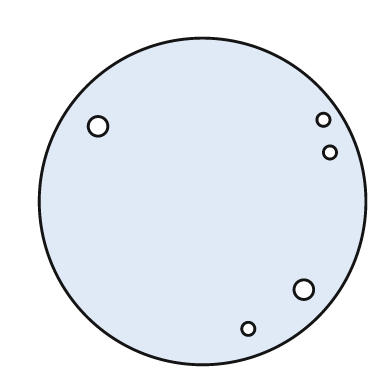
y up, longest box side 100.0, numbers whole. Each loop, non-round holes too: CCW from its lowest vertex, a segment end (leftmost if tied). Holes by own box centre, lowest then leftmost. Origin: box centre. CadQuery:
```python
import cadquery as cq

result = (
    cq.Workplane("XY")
    .moveTo(0.0, 0.0)
    .circle(50.0)
    .moveTo(14.0, -39.0)
    .circle(2.0)
    .moveTo(31.0, -27.0)
    .circle(3.0)
    .moveTo(39.0, 15.0)
    .circle(2.0)
    .moveTo(-32.0, 23.0)
    .circle(3.0)
    .moveTo(37.0, 25.0)
    .circle(2.0)
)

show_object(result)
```